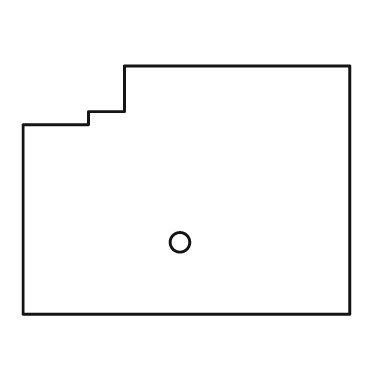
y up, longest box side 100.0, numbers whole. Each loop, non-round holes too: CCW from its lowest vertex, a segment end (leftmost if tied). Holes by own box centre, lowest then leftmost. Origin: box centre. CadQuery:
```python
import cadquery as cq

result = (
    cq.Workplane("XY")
    .moveTo(-50.0, -38.0)
    .lineTo(50.0, -38.0)
    .lineTo(50.0, 38.0)
    .lineTo(-19.0, 38.0)
    .lineTo(-19.0, 24.0)
    .lineTo(-30.0, 24.0)
    .lineTo(-30.0, 20.0)
    .lineTo(-50.0, 20.0)
    .close()
    .moveTo(-2.0, -16.0)
    .circle(3.0)
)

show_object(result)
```